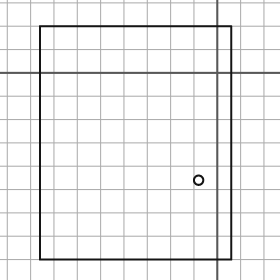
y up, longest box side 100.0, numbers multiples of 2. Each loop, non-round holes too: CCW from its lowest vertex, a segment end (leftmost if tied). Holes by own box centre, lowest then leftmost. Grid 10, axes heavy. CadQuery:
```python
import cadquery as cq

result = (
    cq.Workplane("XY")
    .moveTo(-76.0, -80.0)
    .lineTo(6.0, -80.0)
    .lineTo(6.0, 20.0)
    .lineTo(-76.0, 20.0)
    .close()
    .moveTo(-8.0, -46.0)
    .circle(2.0)
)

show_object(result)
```